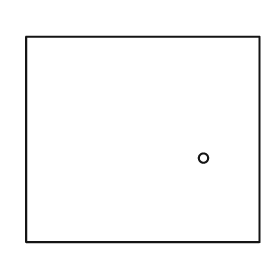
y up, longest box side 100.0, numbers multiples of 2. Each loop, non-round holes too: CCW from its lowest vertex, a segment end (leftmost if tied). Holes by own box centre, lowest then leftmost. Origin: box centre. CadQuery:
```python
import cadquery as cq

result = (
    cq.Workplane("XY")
    .moveTo(-50.0, -44.0)
    .lineTo(50.0, -44.0)
    .lineTo(50.0, 44.0)
    .lineTo(-50.0, 44.0)
    .close()
    .moveTo(26.0, -8.0)
    .circle(2.0)
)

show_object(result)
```